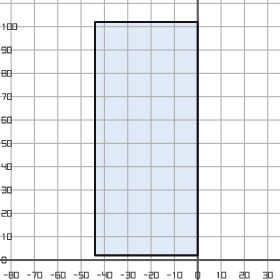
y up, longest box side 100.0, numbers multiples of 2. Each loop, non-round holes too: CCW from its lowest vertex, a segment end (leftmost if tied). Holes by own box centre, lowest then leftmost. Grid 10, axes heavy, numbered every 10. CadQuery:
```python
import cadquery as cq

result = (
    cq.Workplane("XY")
    .moveTo(-44.0, 2.0)
    .lineTo(0.0, 2.0)
    .lineTo(0.0, 102.0)
    .lineTo(-44.0, 102.0)
    .close()
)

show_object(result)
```